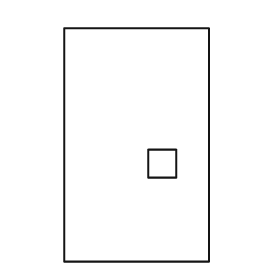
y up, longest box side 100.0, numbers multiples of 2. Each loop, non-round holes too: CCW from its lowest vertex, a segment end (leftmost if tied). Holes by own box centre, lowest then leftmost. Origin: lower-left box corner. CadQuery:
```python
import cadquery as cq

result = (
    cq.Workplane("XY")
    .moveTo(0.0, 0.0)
    .lineTo(62.0, 0.0)
    .lineTo(62.0, 100.0)
    .lineTo(0.0, 100.0)
    .close()
    .moveTo(36.0, 36.0)
    .lineTo(48.0, 36.0)
    .lineTo(48.0, 48.0)
    .lineTo(36.0, 48.0)
    .close()
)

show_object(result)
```